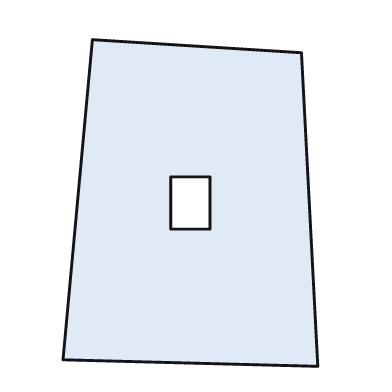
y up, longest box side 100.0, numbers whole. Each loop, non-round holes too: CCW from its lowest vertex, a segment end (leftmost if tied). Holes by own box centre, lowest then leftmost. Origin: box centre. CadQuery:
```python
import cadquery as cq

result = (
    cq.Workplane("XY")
    .moveTo(39.0, -50.0)
    .lineTo(34.0, 46.0)
    .lineTo(-30.0, 50.0)
    .lineTo(-39.0, -48.0)
    .close()
    .moveTo(-6.0, -8.0)
    .lineTo(6.0, -8.0)
    .lineTo(6.0, 8.0)
    .lineTo(-6.0, 8.0)
    .close()
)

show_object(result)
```